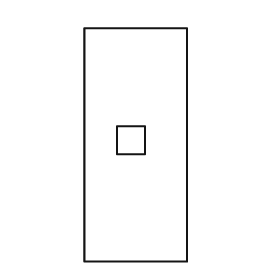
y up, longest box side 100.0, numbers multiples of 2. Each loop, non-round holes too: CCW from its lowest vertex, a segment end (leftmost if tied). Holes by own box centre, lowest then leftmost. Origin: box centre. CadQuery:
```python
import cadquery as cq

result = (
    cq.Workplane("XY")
    .moveTo(-22.0, -50.0)
    .lineTo(22.0, -50.0)
    .lineTo(22.0, 50.0)
    .lineTo(-22.0, 50.0)
    .close()
    .moveTo(-8.0, -4.0)
    .lineTo(4.0, -4.0)
    .lineTo(4.0, 8.0)
    .lineTo(-8.0, 8.0)
    .close()
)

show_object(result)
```